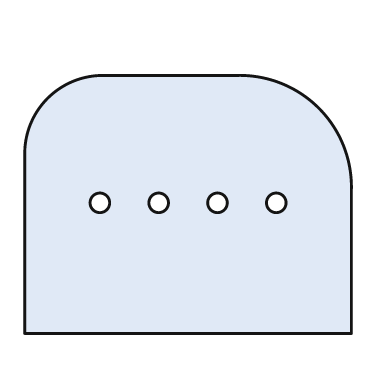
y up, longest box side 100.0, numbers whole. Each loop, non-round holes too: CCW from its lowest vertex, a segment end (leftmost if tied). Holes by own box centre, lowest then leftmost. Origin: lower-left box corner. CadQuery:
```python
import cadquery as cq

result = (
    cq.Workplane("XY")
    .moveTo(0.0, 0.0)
    .lineTo(100.0, 0.0)
    .lineTo(100.0, 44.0)
    .threePointArc((90.0, 69.0), (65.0, 79.0))
    .lineTo(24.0, 79.0)
    .threePointArc((7.0, 72.0), (0.0, 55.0))
    .close()
    .moveTo(23.0, 40.0)
    .circle(3.0)
    .moveTo(41.0, 40.0)
    .circle(3.0)
    .moveTo(59.0, 40.0)
    .circle(3.0)
    .moveTo(77.0, 40.0)
    .circle(3.0)
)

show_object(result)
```